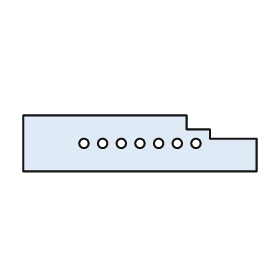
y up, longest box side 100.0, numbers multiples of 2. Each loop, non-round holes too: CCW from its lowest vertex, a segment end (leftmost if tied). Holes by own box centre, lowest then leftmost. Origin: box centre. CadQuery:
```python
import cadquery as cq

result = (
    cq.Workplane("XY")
    .moveTo(-50.0, -12.0)
    .lineTo(50.0, -12.0)
    .lineTo(50.0, 2.0)
    .lineTo(30.0, 2.0)
    .lineTo(30.0, 6.0)
    .lineTo(20.0, 6.0)
    .lineTo(20.0, 12.0)
    .lineTo(-50.0, 12.0)
    .close()
    .moveTo(-24.0, 0.0)
    .circle(2.0)
    .moveTo(-16.0, 0.0)
    .circle(2.0)
    .moveTo(-8.0, 0.0)
    .circle(2.0)
    .moveTo(0.0, 0.0)
    .circle(2.0)
    .moveTo(8.0, 0.0)
    .circle(2.0)
    .moveTo(16.0, 0.0)
    .circle(2.0)
    .moveTo(24.0, 0.0)
    .circle(2.0)
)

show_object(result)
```